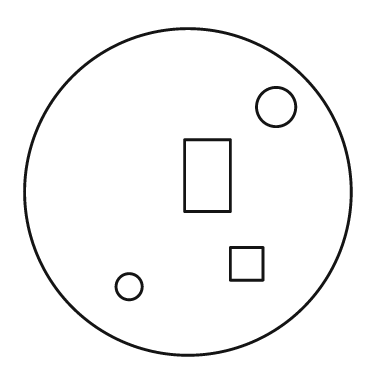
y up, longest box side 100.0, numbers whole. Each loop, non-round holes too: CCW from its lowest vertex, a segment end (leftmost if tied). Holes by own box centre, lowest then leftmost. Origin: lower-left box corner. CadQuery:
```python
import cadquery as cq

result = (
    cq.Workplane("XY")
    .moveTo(50.0, 50.0)
    .circle(50.0)
    .moveTo(32.0, 21.0)
    .circle(4.0)
    .moveTo(63.0, 23.0)
    .lineTo(73.0, 23.0)
    .lineTo(73.0, 33.0)
    .lineTo(63.0, 33.0)
    .close()
    .moveTo(49.0, 44.0)
    .lineTo(63.0, 44.0)
    .lineTo(63.0, 66.0)
    .lineTo(49.0, 66.0)
    .close()
    .moveTo(77.0, 76.0)
    .circle(6.0)
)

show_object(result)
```